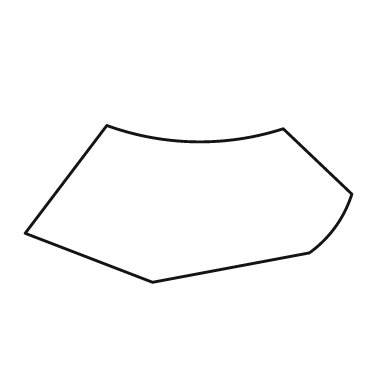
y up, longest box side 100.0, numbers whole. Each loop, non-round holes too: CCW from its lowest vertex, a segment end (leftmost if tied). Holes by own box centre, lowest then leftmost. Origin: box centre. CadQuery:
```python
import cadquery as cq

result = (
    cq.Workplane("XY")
    .moveTo(-11.0, -24.0)
    .lineTo(37.0, -15.0)
    .threePointArc((45.0, -7.0), (50.0, 3.0))
    .lineTo(29.0, 23.0)
    .threePointArc((2.0, 19.0), (-25.0, 24.0))
    .lineTo(-50.0, -9.0)
    .close()
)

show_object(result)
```